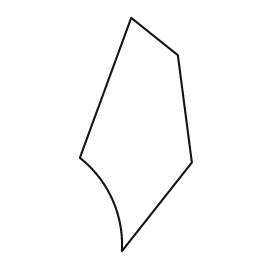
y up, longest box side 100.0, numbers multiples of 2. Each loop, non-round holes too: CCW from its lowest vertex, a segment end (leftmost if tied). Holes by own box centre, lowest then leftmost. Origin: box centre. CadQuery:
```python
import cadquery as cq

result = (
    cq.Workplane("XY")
    .moveTo(-6.0, -50.0)
    .lineTo(24.0, -12.0)
    .lineTo(18.0, 34.0)
    .lineTo(-2.0, 50.0)
    .lineTo(-24.0, -10.0)
    .threePointArc((-10.0, -28.0), (-6.0, -50.0))
    .close()
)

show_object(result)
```